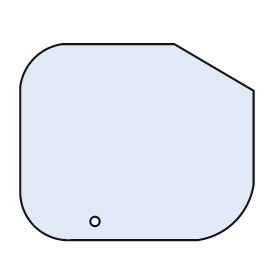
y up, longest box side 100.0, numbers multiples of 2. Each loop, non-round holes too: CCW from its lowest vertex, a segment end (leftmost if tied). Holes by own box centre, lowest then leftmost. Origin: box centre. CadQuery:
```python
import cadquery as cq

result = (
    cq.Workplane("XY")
    .moveTo(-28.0, -42.0)
    .lineTo(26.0, -42.0)
    .threePointArc((42.0, -34.0), (50.0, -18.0))
    .lineTo(50.0, 22.0)
    .lineTo(16.0, 42.0)
    .lineTo(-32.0, 42.0)
    .threePointArc((-44.0, 36.0), (-50.0, 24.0))
    .lineTo(-50.0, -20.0)
    .threePointArc((-44.0, -36.0), (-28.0, -42.0))
    .close()
    .moveTo(-18.0, -34.0)
    .circle(2.0)
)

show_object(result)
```